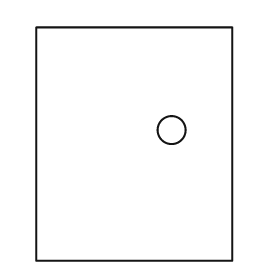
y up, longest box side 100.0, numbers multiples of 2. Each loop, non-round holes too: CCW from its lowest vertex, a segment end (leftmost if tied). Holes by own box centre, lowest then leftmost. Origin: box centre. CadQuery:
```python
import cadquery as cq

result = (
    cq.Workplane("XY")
    .moveTo(-42.0, -50.0)
    .lineTo(42.0, -50.0)
    .lineTo(42.0, 50.0)
    .lineTo(-42.0, 50.0)
    .close()
    .moveTo(16.0, 6.0)
    .circle(6.0)
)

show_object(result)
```